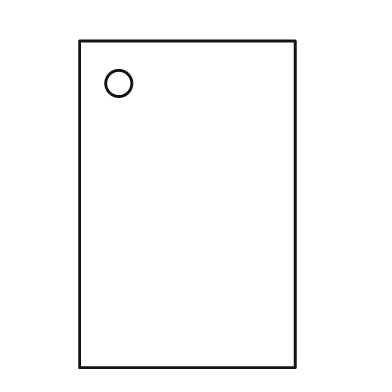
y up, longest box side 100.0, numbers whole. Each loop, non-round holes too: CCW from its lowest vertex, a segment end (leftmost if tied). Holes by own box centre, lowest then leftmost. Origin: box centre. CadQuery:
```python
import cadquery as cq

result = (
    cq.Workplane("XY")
    .moveTo(-33.0, -50.0)
    .lineTo(33.0, -50.0)
    .lineTo(33.0, 50.0)
    .lineTo(-33.0, 50.0)
    .close()
    .moveTo(-21.0, 37.0)
    .circle(4.0)
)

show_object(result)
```